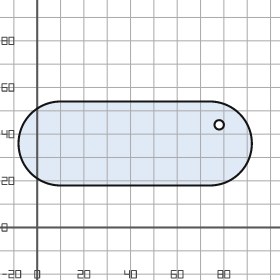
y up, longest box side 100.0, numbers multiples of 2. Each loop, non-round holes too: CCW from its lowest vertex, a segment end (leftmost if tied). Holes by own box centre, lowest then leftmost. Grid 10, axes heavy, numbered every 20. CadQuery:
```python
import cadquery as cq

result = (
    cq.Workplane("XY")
    .moveTo(10.0, 18.0)
    .lineTo(74.0, 18.0)
    .threePointArc((92.0, 36.0), (74.0, 54.0))
    .lineTo(10.0, 54.0)
    .threePointArc((-8.0, 36.0), (10.0, 18.0))
    .close()
    .moveTo(78.0, 44.0)
    .circle(2.0)
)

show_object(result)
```